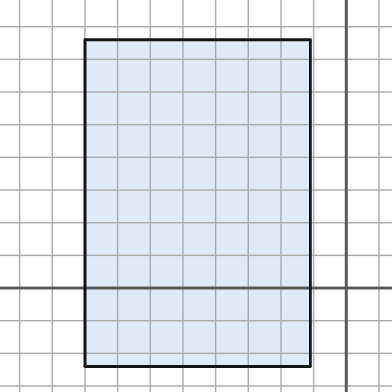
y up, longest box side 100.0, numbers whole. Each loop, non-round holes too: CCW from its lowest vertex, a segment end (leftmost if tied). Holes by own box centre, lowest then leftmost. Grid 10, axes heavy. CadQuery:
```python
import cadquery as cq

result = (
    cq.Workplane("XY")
    .moveTo(-80.0, -24.0)
    .lineTo(-11.0, -24.0)
    .lineTo(-11.0, 76.0)
    .lineTo(-80.0, 76.0)
    .close()
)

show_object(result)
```